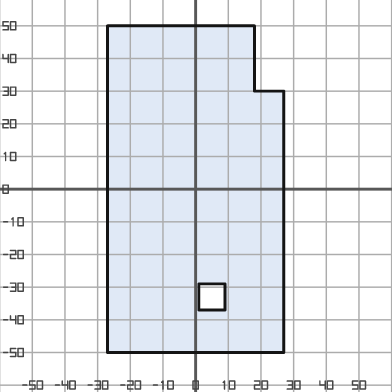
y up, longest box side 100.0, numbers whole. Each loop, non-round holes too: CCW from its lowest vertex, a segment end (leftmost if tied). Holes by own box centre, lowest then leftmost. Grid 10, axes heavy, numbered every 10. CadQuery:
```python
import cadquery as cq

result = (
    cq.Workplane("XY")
    .moveTo(-27.0, -50.0)
    .lineTo(27.0, -50.0)
    .lineTo(27.0, 30.0)
    .lineTo(18.0, 30.0)
    .lineTo(18.0, 50.0)
    .lineTo(-27.0, 50.0)
    .close()
    .moveTo(1.0, -37.0)
    .lineTo(9.0, -37.0)
    .lineTo(9.0, -29.0)
    .lineTo(1.0, -29.0)
    .close()
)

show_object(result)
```